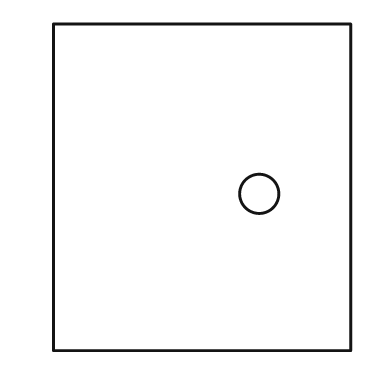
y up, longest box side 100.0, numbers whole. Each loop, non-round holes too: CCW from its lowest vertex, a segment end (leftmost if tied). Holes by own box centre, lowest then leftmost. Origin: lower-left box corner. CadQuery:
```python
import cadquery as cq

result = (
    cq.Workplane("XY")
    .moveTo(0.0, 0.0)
    .lineTo(91.0, 0.0)
    .lineTo(91.0, 100.0)
    .lineTo(0.0, 100.0)
    .close()
    .moveTo(63.0, 48.0)
    .circle(6.0)
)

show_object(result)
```